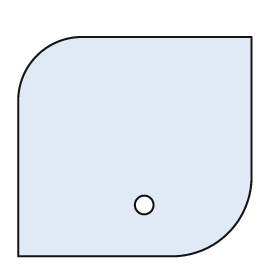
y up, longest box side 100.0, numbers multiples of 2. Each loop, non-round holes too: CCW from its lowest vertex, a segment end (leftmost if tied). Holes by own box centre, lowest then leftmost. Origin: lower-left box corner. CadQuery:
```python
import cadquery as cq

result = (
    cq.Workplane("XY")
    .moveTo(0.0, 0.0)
    .lineTo(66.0, 0.0)
    .threePointArc((90.0, 10.0), (100.0, 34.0))
    .lineTo(100.0, 94.0)
    .lineTo(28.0, 94.0)
    .threePointArc((8.0, 86.0), (0.0, 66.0))
    .close()
    .moveTo(54.0, 22.0)
    .circle(4.0)
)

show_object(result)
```